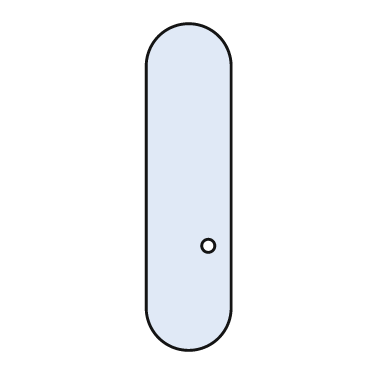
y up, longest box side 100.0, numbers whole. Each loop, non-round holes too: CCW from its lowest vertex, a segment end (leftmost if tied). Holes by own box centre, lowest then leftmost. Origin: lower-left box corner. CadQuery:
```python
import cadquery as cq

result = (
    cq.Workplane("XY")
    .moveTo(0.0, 13.0)
    .threePointArc((13.0, 0.0), (26.0, 13.0))
    .lineTo(26.0, 87.0)
    .threePointArc((13.0, 100.0), (0.0, 87.0))
    .close()
    .moveTo(19.0, 32.0)
    .circle(2.0)
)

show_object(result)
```